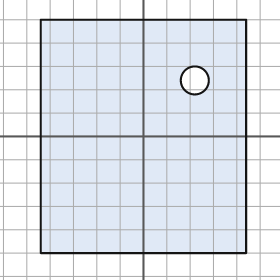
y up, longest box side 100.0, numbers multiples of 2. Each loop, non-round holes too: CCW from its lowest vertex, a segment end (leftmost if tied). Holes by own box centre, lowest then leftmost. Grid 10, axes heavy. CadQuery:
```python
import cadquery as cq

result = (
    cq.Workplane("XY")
    .moveTo(-44.0, -50.0)
    .lineTo(44.0, -50.0)
    .lineTo(44.0, 50.0)
    .lineTo(-44.0, 50.0)
    .close()
    .moveTo(22.0, 24.0)
    .circle(6.0)
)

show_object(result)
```